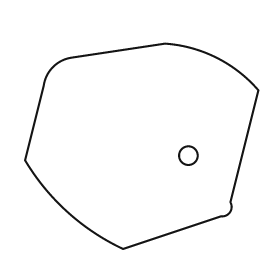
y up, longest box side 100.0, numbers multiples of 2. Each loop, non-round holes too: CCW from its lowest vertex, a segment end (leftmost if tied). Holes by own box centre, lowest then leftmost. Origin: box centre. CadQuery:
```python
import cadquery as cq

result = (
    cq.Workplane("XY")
    .moveTo(-8.0, -44.0)
    .lineTo(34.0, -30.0)
    .threePointArc((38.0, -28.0), (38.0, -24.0))
    .lineTo(50.0, 24.0)
    .threePointArc((32.0, 38.0), (10.0, 44.0))
    .lineTo(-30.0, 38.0)
    .threePointArc((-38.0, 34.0), (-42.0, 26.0))
    .lineTo(-50.0, -6.0)
    .threePointArc((-32.0, -28.0), (-8.0, -44.0))
    .close()
    .moveTo(20.0, -4.0)
    .circle(4.0)
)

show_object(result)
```